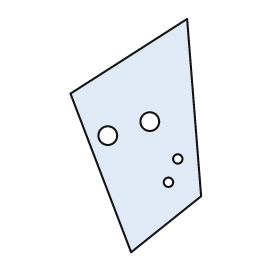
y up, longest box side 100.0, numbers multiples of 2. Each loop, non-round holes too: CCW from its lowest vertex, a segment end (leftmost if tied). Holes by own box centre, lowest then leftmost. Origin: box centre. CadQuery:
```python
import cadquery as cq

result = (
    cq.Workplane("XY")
    .moveTo(-2.0, -50.0)
    .lineTo(28.0, -26.0)
    .lineTo(22.0, 50.0)
    .lineTo(-28.0, 18.0)
    .close()
    .moveTo(14.0, -20.0)
    .circle(2.0)
    .moveTo(18.0, -10.0)
    .circle(2.0)
    .moveTo(-12.0, 0.0)
    .circle(4.0)
    .moveTo(6.0, 6.0)
    .circle(4.0)
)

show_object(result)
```